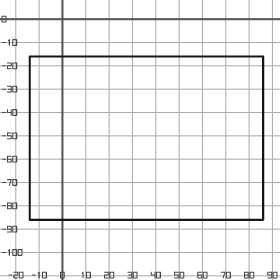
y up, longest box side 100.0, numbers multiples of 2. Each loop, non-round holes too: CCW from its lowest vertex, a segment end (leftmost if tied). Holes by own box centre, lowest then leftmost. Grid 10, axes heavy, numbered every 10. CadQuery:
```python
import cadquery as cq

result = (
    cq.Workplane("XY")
    .moveTo(-14.0, -86.0)
    .lineTo(86.0, -86.0)
    .lineTo(86.0, -16.0)
    .lineTo(-14.0, -16.0)
    .close()
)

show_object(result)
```